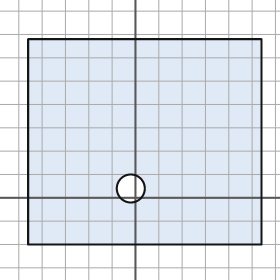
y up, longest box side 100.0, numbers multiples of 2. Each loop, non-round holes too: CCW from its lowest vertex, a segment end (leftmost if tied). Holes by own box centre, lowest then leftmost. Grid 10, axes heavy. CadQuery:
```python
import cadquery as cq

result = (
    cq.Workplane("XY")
    .moveTo(-46.0, -20.0)
    .lineTo(54.0, -20.0)
    .lineTo(54.0, 68.0)
    .lineTo(-46.0, 68.0)
    .close()
    .moveTo(-2.0, 4.0)
    .circle(6.0)
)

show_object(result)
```